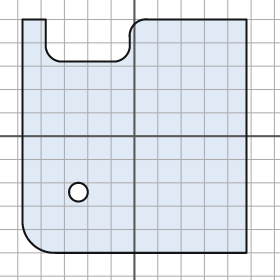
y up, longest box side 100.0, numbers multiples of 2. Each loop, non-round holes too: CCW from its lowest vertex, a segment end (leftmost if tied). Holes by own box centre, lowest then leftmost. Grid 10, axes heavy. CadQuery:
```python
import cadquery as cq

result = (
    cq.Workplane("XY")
    .moveTo(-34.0, -50.0)
    .lineTo(48.0, -50.0)
    .lineTo(48.0, 50.0)
    .lineTo(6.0, 50.0)
    .threePointArc((0.0, 48.0), (-2.0, 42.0))
    .lineTo(-2.0, 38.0)
    .threePointArc((-4.0, 34.0), (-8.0, 32.0))
    .lineTo(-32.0, 32.0)
    .threePointArc((-36.0, 34.0), (-38.0, 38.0))
    .lineTo(-38.0, 50.0)
    .lineTo(-48.0, 50.0)
    .lineTo(-48.0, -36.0)
    .threePointArc((-44.0, -46.0), (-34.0, -50.0))
    .close()
    .moveTo(-24.0, -24.0)
    .circle(4.0)
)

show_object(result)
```